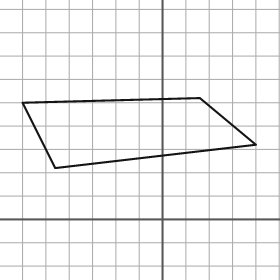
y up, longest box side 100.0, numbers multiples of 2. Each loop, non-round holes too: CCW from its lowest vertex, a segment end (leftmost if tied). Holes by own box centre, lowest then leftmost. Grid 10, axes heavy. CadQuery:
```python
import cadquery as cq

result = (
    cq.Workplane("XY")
    .moveTo(-46.0, 22.0)
    .lineTo(40.0, 32.0)
    .lineTo(16.0, 52.0)
    .lineTo(-60.0, 50.0)
    .close()
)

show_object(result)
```